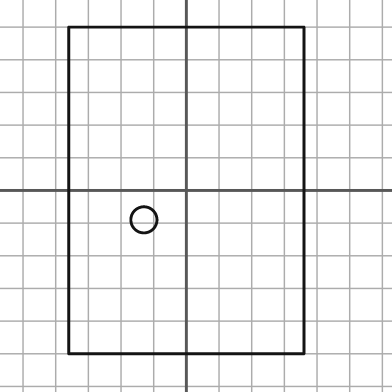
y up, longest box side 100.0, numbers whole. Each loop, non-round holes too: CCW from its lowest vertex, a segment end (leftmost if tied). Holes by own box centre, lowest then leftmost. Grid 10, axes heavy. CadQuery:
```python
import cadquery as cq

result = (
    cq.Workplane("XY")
    .moveTo(-36.0, -50.0)
    .lineTo(36.0, -50.0)
    .lineTo(36.0, 50.0)
    .lineTo(-36.0, 50.0)
    .close()
    .moveTo(-13.0, -9.0)
    .circle(4.0)
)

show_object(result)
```